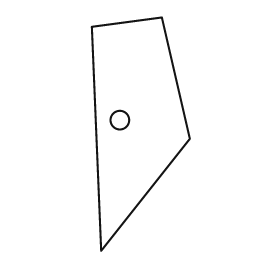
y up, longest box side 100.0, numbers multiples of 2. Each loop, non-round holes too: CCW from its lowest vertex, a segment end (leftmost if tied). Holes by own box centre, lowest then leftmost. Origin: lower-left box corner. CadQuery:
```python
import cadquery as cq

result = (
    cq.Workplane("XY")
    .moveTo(4.0, 0.0)
    .lineTo(42.0, 48.0)
    .lineTo(30.0, 100.0)
    .lineTo(0.0, 96.0)
    .close()
    .moveTo(12.0, 56.0)
    .circle(4.0)
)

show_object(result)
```